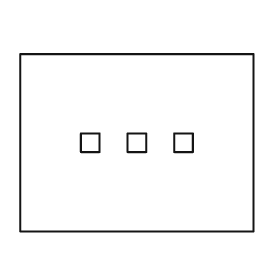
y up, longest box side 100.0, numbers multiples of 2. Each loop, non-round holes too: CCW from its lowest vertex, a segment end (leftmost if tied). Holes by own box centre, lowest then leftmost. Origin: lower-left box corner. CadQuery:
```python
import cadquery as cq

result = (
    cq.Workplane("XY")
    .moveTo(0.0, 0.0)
    .lineTo(100.0, 0.0)
    .lineTo(100.0, 76.0)
    .lineTo(0.0, 76.0)
    .close()
    .moveTo(26.0, 34.0)
    .lineTo(34.0, 34.0)
    .lineTo(34.0, 42.0)
    .lineTo(26.0, 42.0)
    .close()
    .moveTo(46.0, 34.0)
    .lineTo(54.0, 34.0)
    .lineTo(54.0, 42.0)
    .lineTo(46.0, 42.0)
    .close()
    .moveTo(66.0, 34.0)
    .lineTo(74.0, 34.0)
    .lineTo(74.0, 42.0)
    .lineTo(66.0, 42.0)
    .close()
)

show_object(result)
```